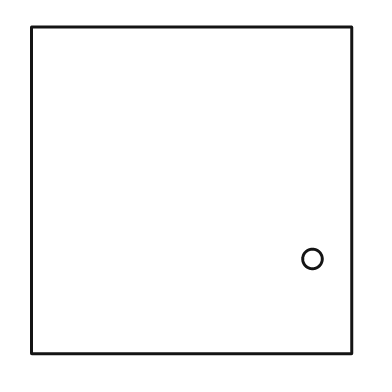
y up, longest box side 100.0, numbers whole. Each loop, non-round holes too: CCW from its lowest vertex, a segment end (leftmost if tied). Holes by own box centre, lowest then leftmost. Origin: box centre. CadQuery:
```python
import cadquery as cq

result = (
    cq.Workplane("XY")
    .moveTo(-49.0, -50.0)
    .lineTo(49.0, -50.0)
    .lineTo(49.0, 50.0)
    .lineTo(-49.0, 50.0)
    .close()
    .moveTo(37.0, -21.0)
    .circle(3.0)
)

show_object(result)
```